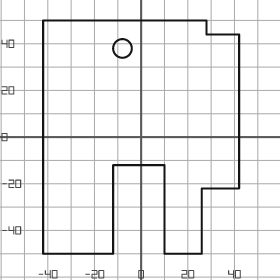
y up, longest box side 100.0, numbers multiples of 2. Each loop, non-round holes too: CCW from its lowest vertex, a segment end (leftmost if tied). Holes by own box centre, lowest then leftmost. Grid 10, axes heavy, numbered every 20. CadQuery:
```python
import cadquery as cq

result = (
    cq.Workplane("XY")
    .moveTo(-42.0, -50.0)
    .lineTo(-12.0, -50.0)
    .lineTo(-12.0, -12.0)
    .lineTo(10.0, -12.0)
    .lineTo(10.0, -50.0)
    .lineTo(26.0, -50.0)
    .lineTo(26.0, -22.0)
    .lineTo(42.0, -22.0)
    .lineTo(42.0, 44.0)
    .lineTo(28.0, 44.0)
    .lineTo(28.0, 50.0)
    .lineTo(-42.0, 50.0)
    .close()
    .moveTo(-8.0, 38.0)
    .circle(4.0)
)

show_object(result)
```